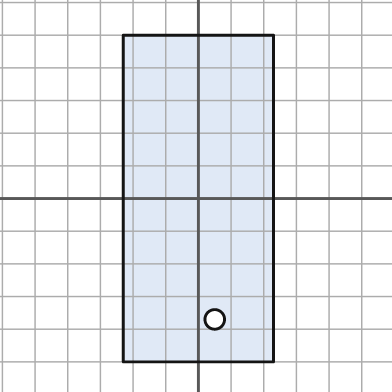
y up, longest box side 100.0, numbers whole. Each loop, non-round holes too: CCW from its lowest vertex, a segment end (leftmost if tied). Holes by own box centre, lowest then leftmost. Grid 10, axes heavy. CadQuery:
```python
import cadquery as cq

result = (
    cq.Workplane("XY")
    .moveTo(-23.0, -50.0)
    .lineTo(23.0, -50.0)
    .lineTo(23.0, 50.0)
    .lineTo(-23.0, 50.0)
    .close()
    .moveTo(5.0, -37.0)
    .circle(3.0)
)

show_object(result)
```